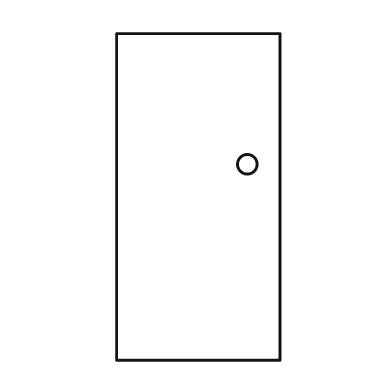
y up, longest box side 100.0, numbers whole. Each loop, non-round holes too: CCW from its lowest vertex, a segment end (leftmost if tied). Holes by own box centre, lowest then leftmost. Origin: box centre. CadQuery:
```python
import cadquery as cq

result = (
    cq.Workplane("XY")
    .moveTo(-25.0, -50.0)
    .lineTo(25.0, -50.0)
    .lineTo(25.0, 50.0)
    .lineTo(-25.0, 50.0)
    .close()
    .moveTo(15.0, 10.0)
    .circle(3.0)
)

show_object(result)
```